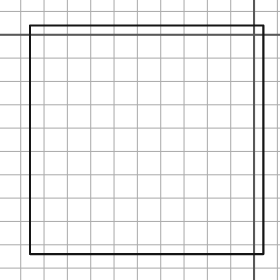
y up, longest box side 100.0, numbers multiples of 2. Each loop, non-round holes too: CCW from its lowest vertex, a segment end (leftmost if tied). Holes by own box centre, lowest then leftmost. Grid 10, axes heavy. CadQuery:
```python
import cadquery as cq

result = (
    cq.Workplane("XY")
    .moveTo(-96.0, -94.0)
    .lineTo(4.0, -94.0)
    .lineTo(4.0, 4.0)
    .lineTo(-96.0, 4.0)
    .close()
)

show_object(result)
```